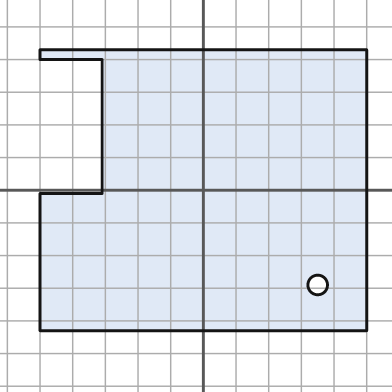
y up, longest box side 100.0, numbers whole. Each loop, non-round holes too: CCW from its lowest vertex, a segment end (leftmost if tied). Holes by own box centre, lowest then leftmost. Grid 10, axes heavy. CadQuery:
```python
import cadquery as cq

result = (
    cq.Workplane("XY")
    .moveTo(-50.0, -43.0)
    .lineTo(50.0, -43.0)
    .lineTo(50.0, 43.0)
    .lineTo(-50.0, 43.0)
    .lineTo(-50.0, 40.0)
    .lineTo(-31.0, 40.0)
    .lineTo(-31.0, -1.0)
    .lineTo(-50.0, -1.0)
    .close()
    .moveTo(35.0, -29.0)
    .circle(3.0)
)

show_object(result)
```